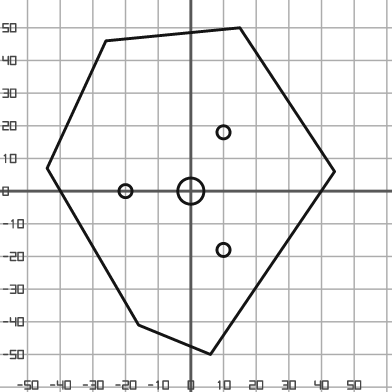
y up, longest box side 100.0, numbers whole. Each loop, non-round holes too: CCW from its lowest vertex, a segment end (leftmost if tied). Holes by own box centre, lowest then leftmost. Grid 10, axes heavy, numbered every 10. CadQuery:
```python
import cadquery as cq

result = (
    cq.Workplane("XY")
    .moveTo(6.0, -50.0)
    .lineTo(44.0, 6.0)
    .lineTo(15.0, 50.0)
    .lineTo(-26.0, 46.0)
    .lineTo(-44.0, 7.0)
    .lineTo(-16.0, -41.0)
    .close()
    .moveTo(10.0, -18.0)
    .circle(2.0)
    .moveTo(-20.0, 0.0)
    .circle(2.0)
    .moveTo(0.0, 0.0)
    .circle(4.0)
    .moveTo(10.0, 18.0)
    .circle(2.0)
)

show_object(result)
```